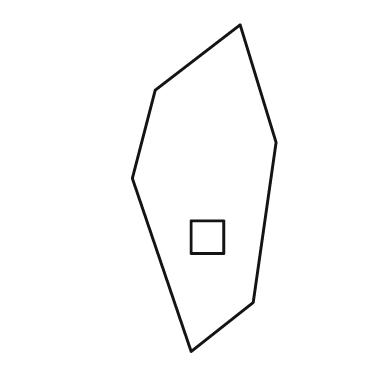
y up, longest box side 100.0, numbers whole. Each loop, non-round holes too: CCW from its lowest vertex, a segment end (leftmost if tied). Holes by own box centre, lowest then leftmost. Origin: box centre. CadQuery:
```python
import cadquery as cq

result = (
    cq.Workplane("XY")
    .moveTo(-4.0, -50.0)
    .lineTo(15.0, -35.0)
    .lineTo(22.0, 14.0)
    .lineTo(11.0, 50.0)
    .lineTo(-15.0, 30.0)
    .lineTo(-22.0, 3.0)
    .close()
    .moveTo(-4.0, -20.0)
    .lineTo(6.0, -20.0)
    .lineTo(6.0, -10.0)
    .lineTo(-4.0, -10.0)
    .close()
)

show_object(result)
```